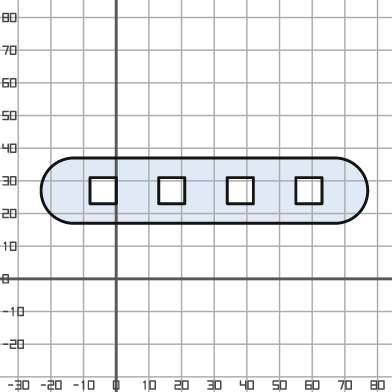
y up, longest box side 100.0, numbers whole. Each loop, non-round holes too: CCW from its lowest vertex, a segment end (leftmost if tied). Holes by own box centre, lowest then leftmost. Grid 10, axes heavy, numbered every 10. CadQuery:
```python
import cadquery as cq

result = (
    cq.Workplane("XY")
    .moveTo(-13.0, 17.0)
    .lineTo(67.0, 17.0)
    .threePointArc((77.0, 27.0), (67.0, 37.0))
    .lineTo(-13.0, 37.0)
    .threePointArc((-23.0, 27.0), (-13.0, 17.0))
    .close()
    .moveTo(-8.0, 23.0)
    .lineTo(0.0, 23.0)
    .lineTo(0.0, 31.0)
    .lineTo(-8.0, 31.0)
    .close()
    .moveTo(13.0, 23.0)
    .lineTo(21.0, 23.0)
    .lineTo(21.0, 31.0)
    .lineTo(13.0, 31.0)
    .close()
    .moveTo(34.0, 23.0)
    .lineTo(42.0, 23.0)
    .lineTo(42.0, 31.0)
    .lineTo(34.0, 31.0)
    .close()
    .moveTo(55.0, 23.0)
    .lineTo(63.0, 23.0)
    .lineTo(63.0, 31.0)
    .lineTo(55.0, 31.0)
    .close()
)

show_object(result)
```